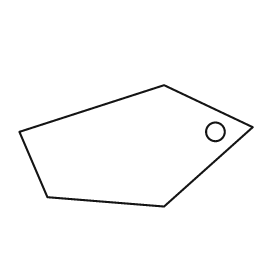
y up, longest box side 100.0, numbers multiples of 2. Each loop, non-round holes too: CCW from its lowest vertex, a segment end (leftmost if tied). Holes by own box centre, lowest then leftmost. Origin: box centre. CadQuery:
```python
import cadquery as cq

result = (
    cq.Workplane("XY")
    .moveTo(12.0, -26.0)
    .lineTo(50.0, 8.0)
    .lineTo(12.0, 26.0)
    .lineTo(-50.0, 6.0)
    .lineTo(-38.0, -22.0)
    .close()
    .moveTo(34.0, 6.0)
    .circle(4.0)
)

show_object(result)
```